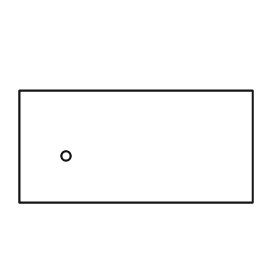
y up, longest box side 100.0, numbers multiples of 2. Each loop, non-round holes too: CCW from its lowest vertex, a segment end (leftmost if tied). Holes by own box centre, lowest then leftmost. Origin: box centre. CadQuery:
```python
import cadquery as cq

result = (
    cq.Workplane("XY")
    .moveTo(-50.0, -24.0)
    .lineTo(50.0, -24.0)
    .lineTo(50.0, 24.0)
    .lineTo(-50.0, 24.0)
    .close()
    .moveTo(-30.0, -4.0)
    .circle(2.0)
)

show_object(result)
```